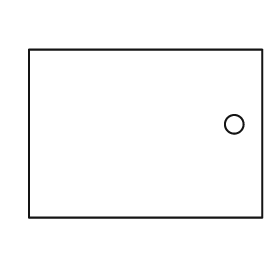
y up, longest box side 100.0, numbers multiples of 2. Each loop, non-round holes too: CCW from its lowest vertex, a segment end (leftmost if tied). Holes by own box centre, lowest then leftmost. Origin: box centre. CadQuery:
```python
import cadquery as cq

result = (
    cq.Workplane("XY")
    .moveTo(-50.0, -36.0)
    .lineTo(50.0, -36.0)
    .lineTo(50.0, 36.0)
    .lineTo(-50.0, 36.0)
    .close()
    .moveTo(38.0, 4.0)
    .circle(4.0)
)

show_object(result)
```